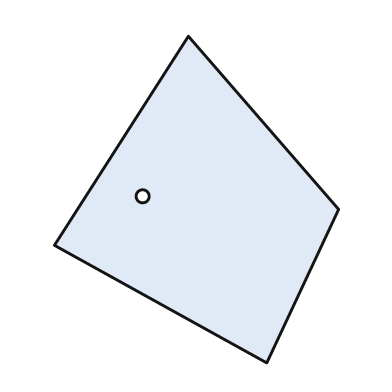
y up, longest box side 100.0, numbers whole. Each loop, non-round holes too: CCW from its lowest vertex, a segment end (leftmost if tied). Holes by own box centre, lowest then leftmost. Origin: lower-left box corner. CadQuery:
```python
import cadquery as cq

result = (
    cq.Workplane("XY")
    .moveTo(65.0, 0.0)
    .lineTo(87.0, 47.0)
    .lineTo(41.0, 100.0)
    .lineTo(0.0, 36.0)
    .close()
    .moveTo(27.0, 51.0)
    .circle(2.0)
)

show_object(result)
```